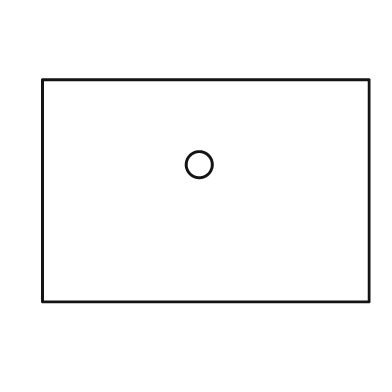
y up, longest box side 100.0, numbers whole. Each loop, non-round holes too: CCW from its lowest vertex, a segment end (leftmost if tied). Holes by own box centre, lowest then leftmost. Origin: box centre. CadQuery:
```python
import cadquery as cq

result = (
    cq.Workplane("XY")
    .moveTo(-50.0, -34.0)
    .lineTo(50.0, -34.0)
    .lineTo(50.0, 34.0)
    .lineTo(-50.0, 34.0)
    .close()
    .moveTo(-2.0, 8.0)
    .circle(4.0)
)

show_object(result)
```